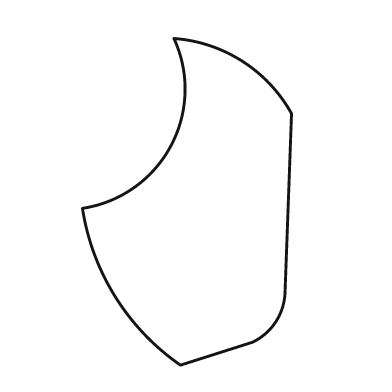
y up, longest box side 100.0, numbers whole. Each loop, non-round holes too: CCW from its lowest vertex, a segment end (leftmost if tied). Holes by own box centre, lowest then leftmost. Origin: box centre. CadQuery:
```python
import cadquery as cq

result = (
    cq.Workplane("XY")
    .moveTo(-2.0, -50.0)
    .lineTo(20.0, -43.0)
    .threePointArc((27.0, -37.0), (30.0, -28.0))
    .lineTo(32.0, 27.0)
    .threePointArc((17.0, 43.0), (-4.0, 50.0))
    .threePointArc((-5.0, 17.0), (-32.0, -2.0))
    .threePointArc((-22.0, -29.0), (-2.0, -50.0))
    .close()
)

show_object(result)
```